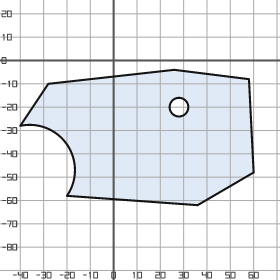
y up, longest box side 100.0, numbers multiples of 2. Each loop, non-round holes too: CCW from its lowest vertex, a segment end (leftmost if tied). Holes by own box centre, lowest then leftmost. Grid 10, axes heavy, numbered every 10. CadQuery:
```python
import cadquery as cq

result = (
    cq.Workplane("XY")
    .moveTo(36.0, -62.0)
    .lineTo(60.0, -48.0)
    .lineTo(58.0, -8.0)
    .lineTo(26.0, -4.0)
    .lineTo(-28.0, -10.0)
    .lineTo(-40.0, -28.0)
    .threePointArc((-20.0, -36.0), (-20.0, -58.0))
    .close()
    .moveTo(28.0, -20.0)
    .circle(4.0)
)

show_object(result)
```